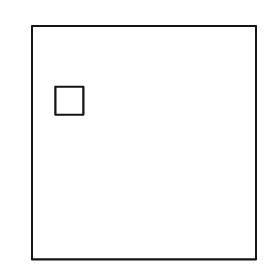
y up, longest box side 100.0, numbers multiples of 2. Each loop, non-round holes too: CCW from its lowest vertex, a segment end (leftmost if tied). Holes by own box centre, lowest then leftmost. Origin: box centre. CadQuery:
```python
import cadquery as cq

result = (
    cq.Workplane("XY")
    .moveTo(-48.0, -50.0)
    .lineTo(48.0, -50.0)
    .lineTo(48.0, 50.0)
    .lineTo(-48.0, 50.0)
    .close()
    .moveTo(-38.0, 12.0)
    .lineTo(-26.0, 12.0)
    .lineTo(-26.0, 24.0)
    .lineTo(-38.0, 24.0)
    .close()
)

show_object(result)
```